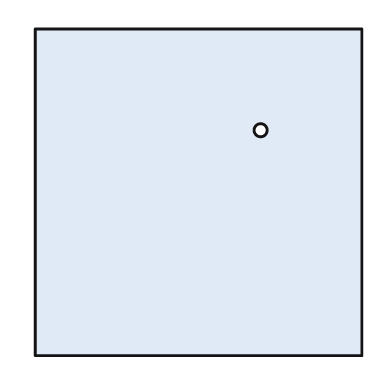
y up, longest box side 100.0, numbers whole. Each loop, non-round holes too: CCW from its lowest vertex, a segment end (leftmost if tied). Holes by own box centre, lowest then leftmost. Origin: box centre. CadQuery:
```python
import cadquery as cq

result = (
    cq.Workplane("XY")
    .moveTo(-50.0, -50.0)
    .lineTo(50.0, -50.0)
    .lineTo(50.0, 50.0)
    .lineTo(-50.0, 50.0)
    .close()
    .moveTo(19.0, 19.0)
    .circle(2.0)
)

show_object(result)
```